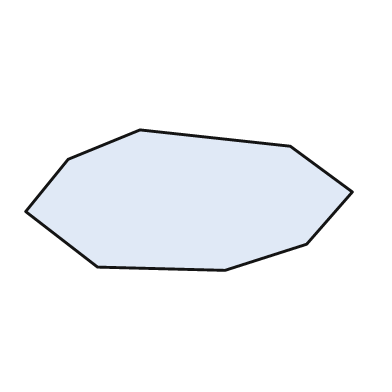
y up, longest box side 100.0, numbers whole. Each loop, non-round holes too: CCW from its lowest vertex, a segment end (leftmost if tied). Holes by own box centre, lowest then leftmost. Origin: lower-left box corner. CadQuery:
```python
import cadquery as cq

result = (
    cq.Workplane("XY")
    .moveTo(61.0, 0.0)
    .lineTo(86.0, 8.0)
    .lineTo(100.0, 24.0)
    .lineTo(81.0, 38.0)
    .lineTo(35.0, 43.0)
    .lineTo(13.0, 34.0)
    .lineTo(0.0, 18.0)
    .lineTo(22.0, 1.0)
    .close()
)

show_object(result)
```